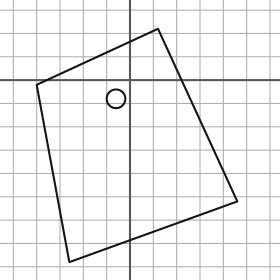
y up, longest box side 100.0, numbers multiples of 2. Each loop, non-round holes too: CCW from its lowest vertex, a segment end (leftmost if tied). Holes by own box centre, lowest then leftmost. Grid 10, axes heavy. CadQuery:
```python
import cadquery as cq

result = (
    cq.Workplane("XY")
    .moveTo(-26.0, -78.0)
    .lineTo(46.0, -52.0)
    .lineTo(12.0, 22.0)
    .lineTo(-40.0, -2.0)
    .close()
    .moveTo(-6.0, -8.0)
    .circle(4.0)
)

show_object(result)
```